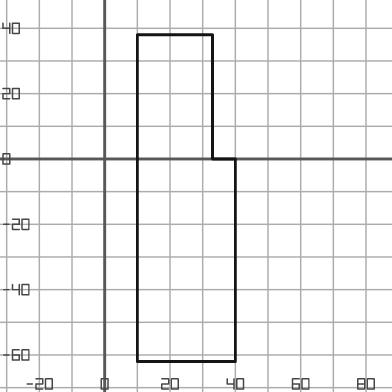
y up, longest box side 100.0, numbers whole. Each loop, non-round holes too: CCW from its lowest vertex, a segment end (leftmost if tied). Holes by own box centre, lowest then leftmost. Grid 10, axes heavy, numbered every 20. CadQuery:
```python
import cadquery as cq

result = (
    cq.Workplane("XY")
    .moveTo(10.0, -62.0)
    .lineTo(40.0, -62.0)
    .lineTo(40.0, 0.0)
    .lineTo(33.0, 0.0)
    .lineTo(33.0, 38.0)
    .lineTo(10.0, 38.0)
    .close()
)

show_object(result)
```